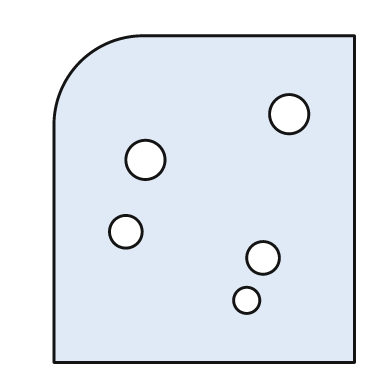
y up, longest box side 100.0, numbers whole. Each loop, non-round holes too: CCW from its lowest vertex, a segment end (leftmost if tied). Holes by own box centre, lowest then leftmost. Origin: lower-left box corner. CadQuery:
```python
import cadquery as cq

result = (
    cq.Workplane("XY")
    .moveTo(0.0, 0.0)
    .lineTo(92.0, 0.0)
    .lineTo(92.0, 100.0)
    .lineTo(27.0, 100.0)
    .threePointArc((8.0, 92.0), (0.0, 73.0))
    .close()
    .moveTo(59.0, 19.0)
    .circle(4.0)
    .moveTo(64.0, 32.0)
    .circle(5.0)
    .moveTo(22.0, 40.0)
    .circle(5.0)
    .moveTo(28.0, 62.0)
    .circle(6.0)
    .moveTo(72.0, 76.0)
    .circle(6.0)
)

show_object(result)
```